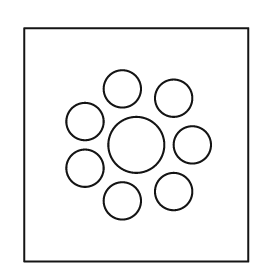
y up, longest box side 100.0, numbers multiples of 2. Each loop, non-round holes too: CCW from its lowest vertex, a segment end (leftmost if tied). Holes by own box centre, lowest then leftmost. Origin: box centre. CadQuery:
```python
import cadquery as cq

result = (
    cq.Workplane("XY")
    .moveTo(-48.0, -50.0)
    .lineTo(48.0, -50.0)
    .lineTo(48.0, 50.0)
    .lineTo(-48.0, 50.0)
    .close()
    .moveTo(-6.0, -24.0)
    .circle(8.0)
    .moveTo(16.0, -20.0)
    .circle(8.0)
    .moveTo(-22.0, -10.0)
    .circle(8.0)
    .moveTo(0.0, 0.0)
    .circle(12.0)
    .moveTo(24.0, 0.0)
    .circle(8.0)
    .moveTo(-22.0, 10.0)
    .circle(8.0)
    .moveTo(16.0, 20.0)
    .circle(8.0)
    .moveTo(-6.0, 24.0)
    .circle(8.0)
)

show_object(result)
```